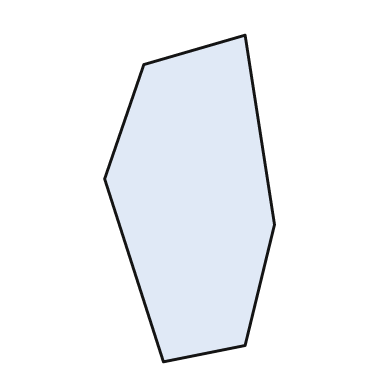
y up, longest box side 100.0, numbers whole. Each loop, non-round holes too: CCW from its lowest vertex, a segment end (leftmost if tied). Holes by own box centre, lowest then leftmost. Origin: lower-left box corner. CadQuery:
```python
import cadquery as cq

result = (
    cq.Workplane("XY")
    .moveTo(18.0, 0.0)
    .lineTo(43.0, 5.0)
    .lineTo(52.0, 42.0)
    .lineTo(43.0, 100.0)
    .lineTo(12.0, 91.0)
    .lineTo(0.0, 56.0)
    .close()
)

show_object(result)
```